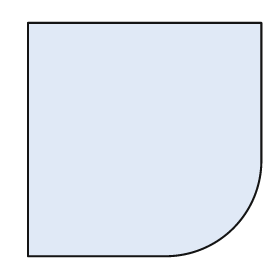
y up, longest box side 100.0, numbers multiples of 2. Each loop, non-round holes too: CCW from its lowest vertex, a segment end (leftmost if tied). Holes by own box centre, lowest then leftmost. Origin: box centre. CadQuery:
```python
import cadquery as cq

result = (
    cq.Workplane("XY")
    .moveTo(-50.0, -50.0)
    .lineTo(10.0, -50.0)
    .threePointArc((38.0, -38.0), (50.0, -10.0))
    .lineTo(50.0, 50.0)
    .lineTo(-50.0, 50.0)
    .close()
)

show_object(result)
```